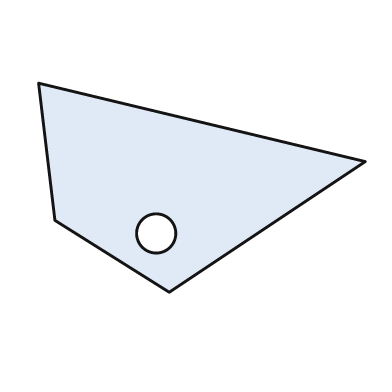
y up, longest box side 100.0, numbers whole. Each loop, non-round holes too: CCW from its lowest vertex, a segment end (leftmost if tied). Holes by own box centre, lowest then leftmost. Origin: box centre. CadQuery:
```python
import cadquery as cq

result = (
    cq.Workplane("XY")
    .moveTo(-10.0, -32.0)
    .lineTo(50.0, 8.0)
    .lineTo(-50.0, 32.0)
    .lineTo(-45.0, -10.0)
    .close()
    .moveTo(-14.0, -14.0)
    .circle(6.0)
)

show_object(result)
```